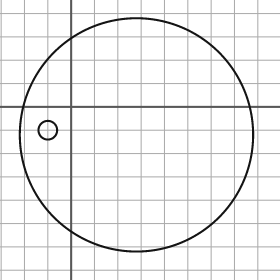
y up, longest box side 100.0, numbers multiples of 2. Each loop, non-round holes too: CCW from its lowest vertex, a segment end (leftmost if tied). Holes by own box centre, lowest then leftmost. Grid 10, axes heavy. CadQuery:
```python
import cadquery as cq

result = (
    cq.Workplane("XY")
    .moveTo(28.0, -12.0)
    .circle(50.0)
    .moveTo(-10.0, -10.0)
    .circle(4.0)
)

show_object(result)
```